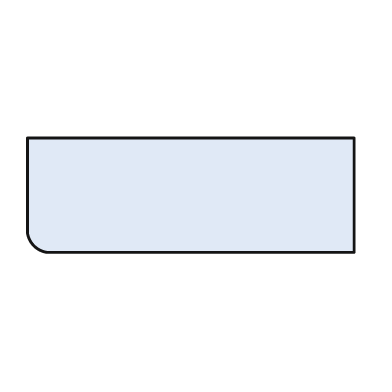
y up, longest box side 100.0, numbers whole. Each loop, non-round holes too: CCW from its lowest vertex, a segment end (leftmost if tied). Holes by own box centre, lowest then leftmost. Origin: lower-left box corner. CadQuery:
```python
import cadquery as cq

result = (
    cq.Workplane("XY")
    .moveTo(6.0, 0.0)
    .lineTo(100.0, 0.0)
    .lineTo(100.0, 35.0)
    .lineTo(0.0, 35.0)
    .lineTo(0.0, 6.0)
    .threePointArc((2.0, 2.0), (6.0, 0.0))
    .close()
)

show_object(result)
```